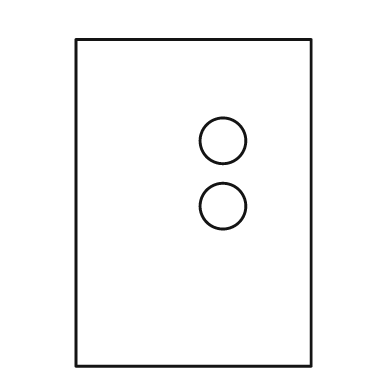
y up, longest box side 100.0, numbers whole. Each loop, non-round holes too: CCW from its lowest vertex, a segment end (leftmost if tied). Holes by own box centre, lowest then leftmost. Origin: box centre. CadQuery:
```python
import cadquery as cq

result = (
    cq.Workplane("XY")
    .moveTo(-36.0, -50.0)
    .lineTo(36.0, -50.0)
    .lineTo(36.0, 50.0)
    .lineTo(-36.0, 50.0)
    .close()
    .moveTo(9.0, -1.0)
    .circle(7.0)
    .moveTo(9.0, 19.0)
    .circle(7.0)
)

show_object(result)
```